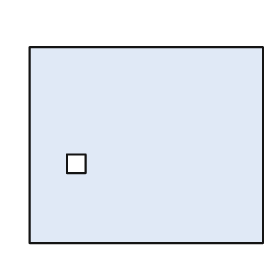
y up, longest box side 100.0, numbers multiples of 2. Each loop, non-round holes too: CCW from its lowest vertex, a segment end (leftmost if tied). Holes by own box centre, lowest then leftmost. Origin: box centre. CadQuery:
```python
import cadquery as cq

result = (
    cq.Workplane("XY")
    .moveTo(-50.0, -42.0)
    .lineTo(50.0, -42.0)
    .lineTo(50.0, 42.0)
    .lineTo(-50.0, 42.0)
    .close()
    .moveTo(-34.0, -12.0)
    .lineTo(-26.0, -12.0)
    .lineTo(-26.0, -4.0)
    .lineTo(-34.0, -4.0)
    .close()
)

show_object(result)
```